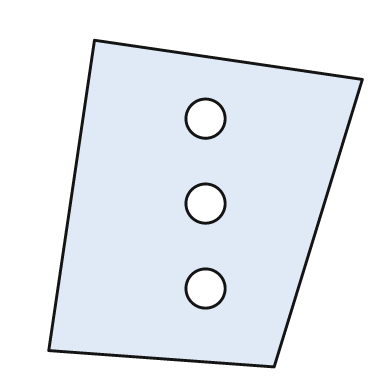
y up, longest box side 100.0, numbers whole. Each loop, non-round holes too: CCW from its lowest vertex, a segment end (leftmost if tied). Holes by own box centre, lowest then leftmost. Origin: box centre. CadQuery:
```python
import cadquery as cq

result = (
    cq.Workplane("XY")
    .moveTo(21.0, -50.0)
    .lineTo(48.0, 38.0)
    .lineTo(-34.0, 50.0)
    .lineTo(-48.0, -45.0)
    .close()
    .moveTo(0.0, -26.0)
    .circle(6.0)
    .moveTo(0.0, 0.0)
    .circle(6.0)
    .moveTo(0.0, 26.0)
    .circle(6.0)
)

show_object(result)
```